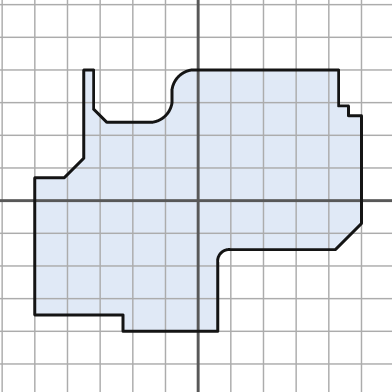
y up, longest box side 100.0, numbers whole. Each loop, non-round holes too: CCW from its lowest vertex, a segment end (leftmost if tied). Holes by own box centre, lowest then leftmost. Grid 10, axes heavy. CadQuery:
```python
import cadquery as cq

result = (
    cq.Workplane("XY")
    .moveTo(-23.0, -40.0)
    .lineTo(6.0, -40.0)
    .lineTo(6.0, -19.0)
    .threePointArc((7.0, -16.0), (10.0, -15.0))
    .lineTo(42.0, -15.0)
    .lineTo(50.0, -7.0)
    .lineTo(50.0, 26.0)
    .lineTo(46.0, 26.0)
    .lineTo(46.0, 29.0)
    .lineTo(43.0, 29.0)
    .lineTo(43.0, 40.0)
    .lineTo(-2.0, 40.0)
    .threePointArc((-6.0, 38.0), (-8.0, 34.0))
    .lineTo(-8.0, 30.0)
    .threePointArc((-10.0, 26.0), (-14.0, 24.0))
    .lineTo(-28.0, 24.0)
    .lineTo(-32.0, 28.0)
    .lineTo(-32.0, 40.0)
    .lineTo(-35.0, 40.0)
    .lineTo(-35.0, 13.0)
    .lineTo(-41.0, 7.0)
    .lineTo(-50.0, 7.0)
    .lineTo(-50.0, -35.0)
    .lineTo(-23.0, -35.0)
    .close()
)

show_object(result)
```